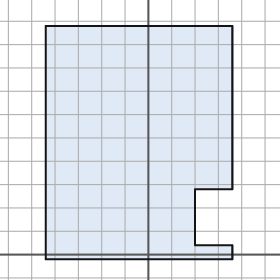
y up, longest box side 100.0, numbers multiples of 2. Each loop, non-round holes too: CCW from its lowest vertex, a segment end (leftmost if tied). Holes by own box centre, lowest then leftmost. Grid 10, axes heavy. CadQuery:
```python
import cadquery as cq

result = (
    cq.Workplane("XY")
    .moveTo(-44.0, -2.0)
    .lineTo(36.0, -2.0)
    .lineTo(36.0, 4.0)
    .lineTo(20.0, 4.0)
    .lineTo(20.0, 28.0)
    .lineTo(36.0, 28.0)
    .lineTo(36.0, 98.0)
    .lineTo(-44.0, 98.0)
    .close()
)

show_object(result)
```